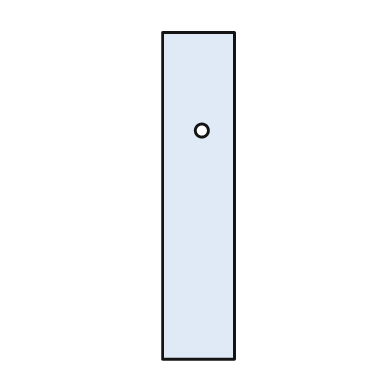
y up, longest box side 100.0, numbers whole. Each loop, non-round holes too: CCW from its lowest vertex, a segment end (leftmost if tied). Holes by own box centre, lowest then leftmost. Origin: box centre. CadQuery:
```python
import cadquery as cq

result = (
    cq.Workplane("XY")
    .moveTo(-11.0, -50.0)
    .lineTo(11.0, -50.0)
    .lineTo(11.0, 50.0)
    .lineTo(-11.0, 50.0)
    .close()
    .moveTo(1.0, 20.0)
    .circle(2.0)
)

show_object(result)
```